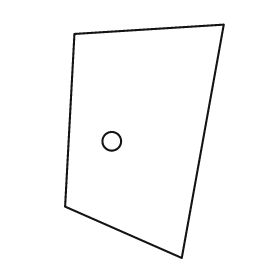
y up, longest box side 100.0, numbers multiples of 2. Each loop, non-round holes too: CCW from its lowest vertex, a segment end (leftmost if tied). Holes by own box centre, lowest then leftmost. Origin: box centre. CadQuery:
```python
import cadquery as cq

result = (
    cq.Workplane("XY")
    .moveTo(16.0, -50.0)
    .lineTo(34.0, 50.0)
    .lineTo(-30.0, 46.0)
    .lineTo(-34.0, -28.0)
    .close()
    .moveTo(-14.0, 0.0)
    .circle(4.0)
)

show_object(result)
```